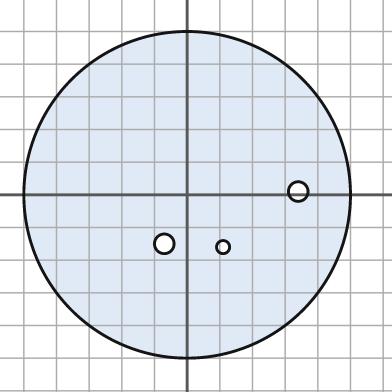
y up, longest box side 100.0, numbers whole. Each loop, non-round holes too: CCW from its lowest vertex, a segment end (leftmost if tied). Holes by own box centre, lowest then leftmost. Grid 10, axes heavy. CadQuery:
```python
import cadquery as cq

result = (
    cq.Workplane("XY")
    .moveTo(0.0, 0.0)
    .circle(50.0)
    .moveTo(11.0, -16.0)
    .circle(2.0)
    .moveTo(-7.0, -15.0)
    .circle(3.0)
    .moveTo(34.0, 1.0)
    .circle(3.0)
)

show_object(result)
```